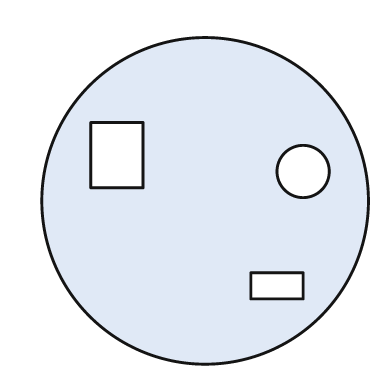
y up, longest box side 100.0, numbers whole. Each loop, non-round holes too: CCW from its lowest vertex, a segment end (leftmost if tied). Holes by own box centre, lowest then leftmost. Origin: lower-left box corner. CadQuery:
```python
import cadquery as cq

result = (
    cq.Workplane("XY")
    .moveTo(50.0, 50.0)
    .circle(50.0)
    .moveTo(64.0, 20.0)
    .lineTo(80.0, 20.0)
    .lineTo(80.0, 28.0)
    .lineTo(64.0, 28.0)
    .close()
    .moveTo(80.0, 59.0)
    .circle(8.0)
    .moveTo(15.0, 54.0)
    .lineTo(31.0, 54.0)
    .lineTo(31.0, 74.0)
    .lineTo(15.0, 74.0)
    .close()
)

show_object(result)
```